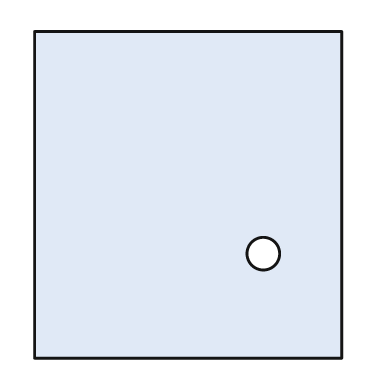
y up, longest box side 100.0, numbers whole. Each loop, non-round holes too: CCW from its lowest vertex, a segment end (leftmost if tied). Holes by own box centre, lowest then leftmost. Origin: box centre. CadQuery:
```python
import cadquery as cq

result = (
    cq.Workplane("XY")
    .moveTo(-47.0, -50.0)
    .lineTo(47.0, -50.0)
    .lineTo(47.0, 50.0)
    .lineTo(-47.0, 50.0)
    .close()
    .moveTo(23.0, -18.0)
    .circle(5.0)
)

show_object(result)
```